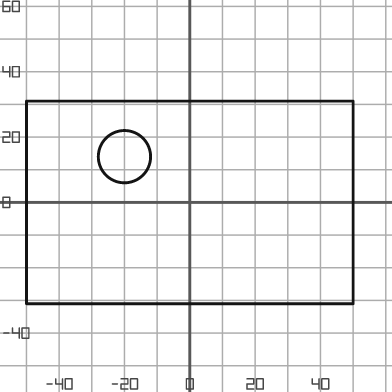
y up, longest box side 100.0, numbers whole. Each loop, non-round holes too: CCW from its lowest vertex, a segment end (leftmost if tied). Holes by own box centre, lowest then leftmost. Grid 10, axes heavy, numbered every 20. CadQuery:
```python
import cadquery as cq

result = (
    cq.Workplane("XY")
    .moveTo(-50.0, -31.0)
    .lineTo(50.0, -31.0)
    .lineTo(50.0, 31.0)
    .lineTo(-50.0, 31.0)
    .close()
    .moveTo(-20.0, 14.0)
    .circle(8.0)
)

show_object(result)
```